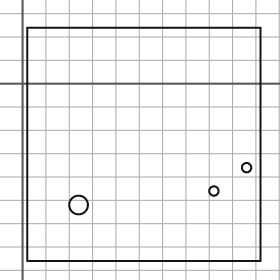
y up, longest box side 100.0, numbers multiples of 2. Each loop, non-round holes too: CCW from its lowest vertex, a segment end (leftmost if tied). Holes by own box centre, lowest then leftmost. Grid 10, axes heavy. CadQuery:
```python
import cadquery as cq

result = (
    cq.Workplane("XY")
    .moveTo(2.0, -76.0)
    .lineTo(102.0, -76.0)
    .lineTo(102.0, 24.0)
    .lineTo(2.0, 24.0)
    .close()
    .moveTo(24.0, -52.0)
    .circle(4.0)
    .moveTo(82.0, -46.0)
    .circle(2.0)
    .moveTo(96.0, -36.0)
    .circle(2.0)
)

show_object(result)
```